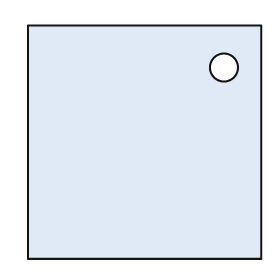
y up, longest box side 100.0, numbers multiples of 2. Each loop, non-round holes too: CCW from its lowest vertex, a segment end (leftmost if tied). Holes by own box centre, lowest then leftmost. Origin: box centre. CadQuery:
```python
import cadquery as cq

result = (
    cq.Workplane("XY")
    .moveTo(-50.0, -50.0)
    .lineTo(50.0, -50.0)
    .lineTo(50.0, 50.0)
    .lineTo(-50.0, 50.0)
    .close()
    .moveTo(34.0, 32.0)
    .circle(6.0)
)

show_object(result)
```